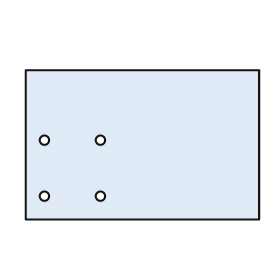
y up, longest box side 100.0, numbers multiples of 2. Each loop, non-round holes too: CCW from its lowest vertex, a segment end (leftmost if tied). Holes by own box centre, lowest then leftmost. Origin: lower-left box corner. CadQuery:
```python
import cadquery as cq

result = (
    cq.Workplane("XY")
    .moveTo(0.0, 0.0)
    .lineTo(100.0, 0.0)
    .lineTo(100.0, 64.0)
    .lineTo(0.0, 64.0)
    .close()
    .moveTo(8.0, 10.0)
    .circle(2.0)
    .moveTo(32.0, 10.0)
    .circle(2.0)
    .moveTo(8.0, 34.0)
    .circle(2.0)
    .moveTo(32.0, 34.0)
    .circle(2.0)
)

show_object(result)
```